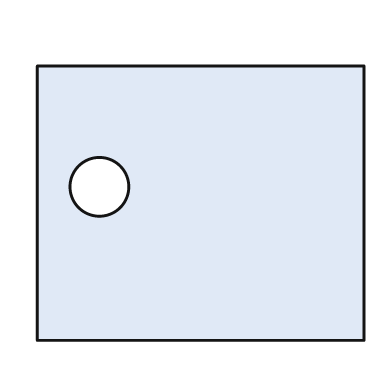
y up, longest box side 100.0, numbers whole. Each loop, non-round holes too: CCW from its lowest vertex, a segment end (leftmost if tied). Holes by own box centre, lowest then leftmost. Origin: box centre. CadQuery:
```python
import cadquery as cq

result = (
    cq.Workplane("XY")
    .moveTo(-50.0, -42.0)
    .lineTo(50.0, -42.0)
    .lineTo(50.0, 42.0)
    .lineTo(-50.0, 42.0)
    .close()
    .moveTo(-31.0, 5.0)
    .circle(9.0)
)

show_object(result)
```